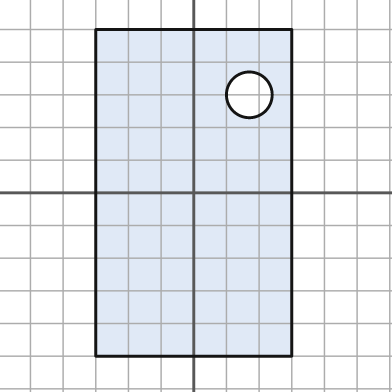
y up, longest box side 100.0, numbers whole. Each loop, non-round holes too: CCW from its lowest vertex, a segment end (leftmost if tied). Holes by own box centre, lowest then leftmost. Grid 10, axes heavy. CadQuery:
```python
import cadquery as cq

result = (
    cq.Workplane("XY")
    .moveTo(-30.0, -50.0)
    .lineTo(30.0, -50.0)
    .lineTo(30.0, 50.0)
    .lineTo(-30.0, 50.0)
    .close()
    .moveTo(17.0, 30.0)
    .circle(7.0)
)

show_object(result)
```